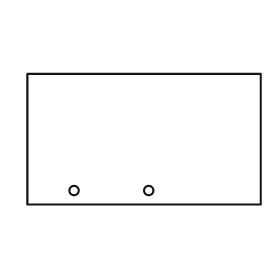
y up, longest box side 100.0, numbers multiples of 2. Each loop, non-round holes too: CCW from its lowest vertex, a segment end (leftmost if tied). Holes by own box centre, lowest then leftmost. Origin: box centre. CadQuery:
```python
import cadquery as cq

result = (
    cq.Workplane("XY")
    .moveTo(-50.0, -28.0)
    .lineTo(50.0, -28.0)
    .lineTo(50.0, 28.0)
    .lineTo(-50.0, 28.0)
    .close()
    .moveTo(-30.0, -22.0)
    .circle(2.0)
    .moveTo(2.0, -22.0)
    .circle(2.0)
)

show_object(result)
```